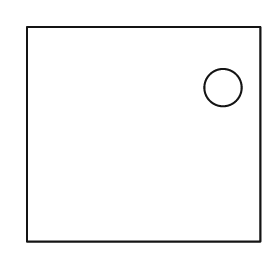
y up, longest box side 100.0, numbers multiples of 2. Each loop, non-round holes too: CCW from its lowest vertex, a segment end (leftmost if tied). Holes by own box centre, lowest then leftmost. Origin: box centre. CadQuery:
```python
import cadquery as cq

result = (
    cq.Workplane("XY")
    .moveTo(-50.0, -46.0)
    .lineTo(50.0, -46.0)
    .lineTo(50.0, 46.0)
    .lineTo(-50.0, 46.0)
    .close()
    .moveTo(34.0, 20.0)
    .circle(8.0)
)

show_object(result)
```